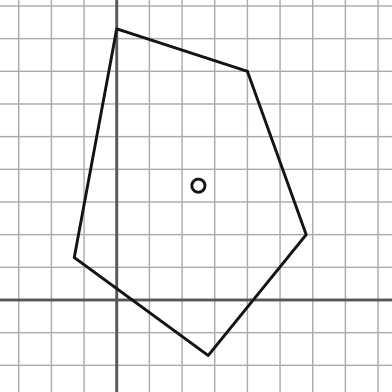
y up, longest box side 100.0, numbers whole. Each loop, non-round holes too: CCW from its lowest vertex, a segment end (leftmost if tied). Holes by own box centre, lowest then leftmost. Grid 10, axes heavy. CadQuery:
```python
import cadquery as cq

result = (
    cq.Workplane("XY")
    .moveTo(28.0, -17.0)
    .lineTo(58.0, 20.0)
    .lineTo(40.0, 70.0)
    .lineTo(0.0, 83.0)
    .lineTo(-13.0, 13.0)
    .close()
    .moveTo(25.0, 35.0)
    .circle(2.0)
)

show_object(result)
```